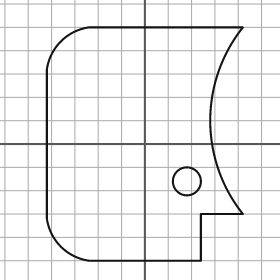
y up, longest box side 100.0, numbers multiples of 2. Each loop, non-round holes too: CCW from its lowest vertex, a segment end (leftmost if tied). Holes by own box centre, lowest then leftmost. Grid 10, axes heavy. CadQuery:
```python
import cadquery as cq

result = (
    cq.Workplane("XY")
    .moveTo(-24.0, -50.0)
    .lineTo(24.0, -50.0)
    .lineTo(24.0, -30.0)
    .lineTo(42.0, -30.0)
    .threePointArc((28.0, 10.0), (42.0, 50.0))
    .lineTo(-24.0, 50.0)
    .threePointArc((-36.0, 44.0), (-42.0, 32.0))
    .lineTo(-42.0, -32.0)
    .threePointArc((-36.0, -44.0), (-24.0, -50.0))
    .close()
    .moveTo(18.0, -16.0)
    .circle(6.0)
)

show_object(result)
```